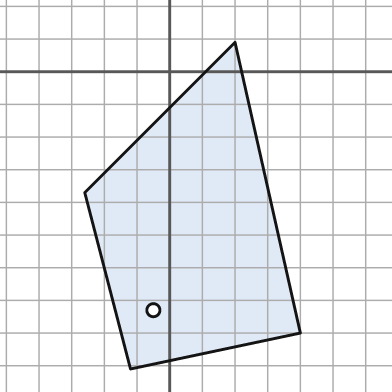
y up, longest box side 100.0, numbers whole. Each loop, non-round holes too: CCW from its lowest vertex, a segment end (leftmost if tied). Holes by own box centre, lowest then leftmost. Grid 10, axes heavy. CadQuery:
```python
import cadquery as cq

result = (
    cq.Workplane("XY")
    .moveTo(-12.0, -91.0)
    .lineTo(40.0, -80.0)
    .lineTo(20.0, 9.0)
    .lineTo(-26.0, -37.0)
    .close()
    .moveTo(-5.0, -73.0)
    .circle(2.0)
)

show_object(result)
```